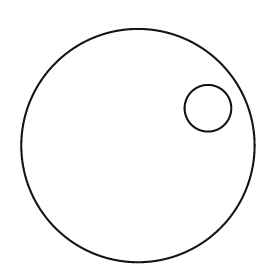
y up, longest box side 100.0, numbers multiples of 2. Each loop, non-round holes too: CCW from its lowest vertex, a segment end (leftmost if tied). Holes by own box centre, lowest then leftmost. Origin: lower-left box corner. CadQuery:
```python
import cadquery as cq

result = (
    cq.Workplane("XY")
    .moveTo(50.0, 50.0)
    .circle(50.0)
    .moveTo(80.0, 66.0)
    .circle(10.0)
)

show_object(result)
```